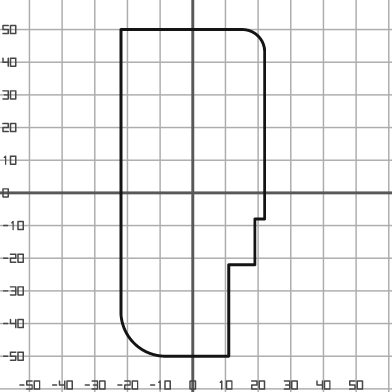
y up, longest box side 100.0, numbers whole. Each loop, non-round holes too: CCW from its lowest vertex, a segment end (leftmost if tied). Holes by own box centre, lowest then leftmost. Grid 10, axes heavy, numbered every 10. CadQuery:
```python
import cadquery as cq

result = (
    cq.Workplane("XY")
    .moveTo(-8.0, -50.0)
    .lineTo(11.0, -50.0)
    .lineTo(11.0, -22.0)
    .lineTo(19.0, -22.0)
    .lineTo(19.0, -8.0)
    .lineTo(22.0, -8.0)
    .lineTo(22.0, 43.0)
    .threePointArc((20.0, 48.0), (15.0, 50.0))
    .lineTo(-22.0, 50.0)
    .lineTo(-22.0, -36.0)
    .threePointArc((-18.0, -46.0), (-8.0, -50.0))
    .close()
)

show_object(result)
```